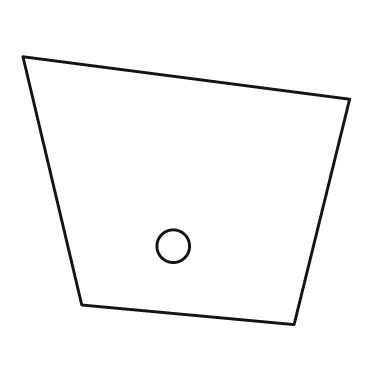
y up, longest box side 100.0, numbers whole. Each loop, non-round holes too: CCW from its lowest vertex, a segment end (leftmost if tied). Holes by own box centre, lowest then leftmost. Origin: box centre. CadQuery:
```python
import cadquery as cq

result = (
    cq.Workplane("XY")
    .moveTo(33.0, -41.0)
    .lineTo(50.0, 28.0)
    .lineTo(-50.0, 41.0)
    .lineTo(-32.0, -35.0)
    .close()
    .moveTo(-4.0, -17.0)
    .circle(5.0)
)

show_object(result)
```